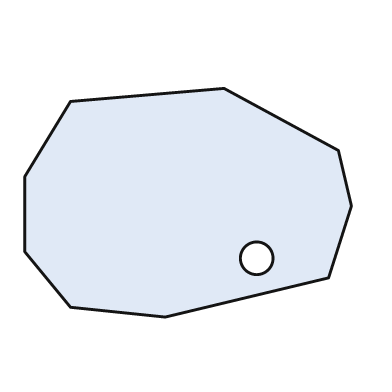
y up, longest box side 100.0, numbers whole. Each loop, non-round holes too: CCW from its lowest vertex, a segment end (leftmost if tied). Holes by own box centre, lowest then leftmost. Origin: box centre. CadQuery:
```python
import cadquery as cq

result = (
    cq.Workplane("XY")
    .moveTo(-7.0, -35.0)
    .lineTo(43.0, -23.0)
    .lineTo(50.0, -1.0)
    .lineTo(46.0, 16.0)
    .lineTo(11.0, 35.0)
    .lineTo(-36.0, 31.0)
    .lineTo(-50.0, 8.0)
    .lineTo(-50.0, -15.0)
    .lineTo(-36.0, -32.0)
    .close()
    .moveTo(21.0, -17.0)
    .circle(5.0)
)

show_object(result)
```